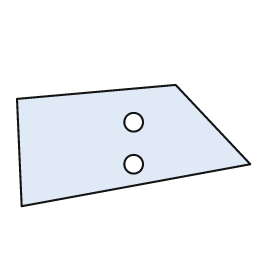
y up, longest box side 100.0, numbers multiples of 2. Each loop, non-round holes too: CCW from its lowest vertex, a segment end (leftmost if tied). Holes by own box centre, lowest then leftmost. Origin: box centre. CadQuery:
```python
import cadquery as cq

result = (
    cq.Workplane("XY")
    .moveTo(-48.0, -26.0)
    .lineTo(50.0, -8.0)
    .lineTo(18.0, 26.0)
    .lineTo(-50.0, 20.0)
    .close()
    .moveTo(0.0, -8.0)
    .circle(4.0)
    .moveTo(0.0, 10.0)
    .circle(4.0)
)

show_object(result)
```